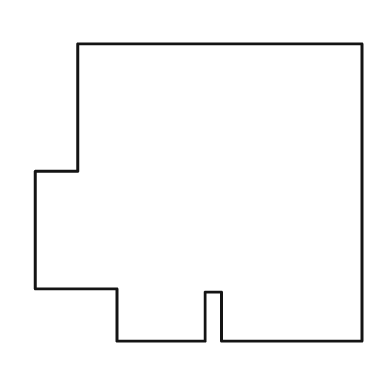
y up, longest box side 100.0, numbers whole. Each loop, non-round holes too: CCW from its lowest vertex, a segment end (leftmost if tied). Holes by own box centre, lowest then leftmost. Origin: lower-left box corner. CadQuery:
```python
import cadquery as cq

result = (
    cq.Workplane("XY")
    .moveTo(25.0, 0.0)
    .lineTo(52.0, 0.0)
    .lineTo(52.0, 15.0)
    .lineTo(57.0, 15.0)
    .lineTo(57.0, 0.0)
    .lineTo(100.0, 0.0)
    .lineTo(100.0, 91.0)
    .lineTo(13.0, 91.0)
    .lineTo(13.0, 52.0)
    .lineTo(0.0, 52.0)
    .lineTo(0.0, 16.0)
    .lineTo(25.0, 16.0)
    .close()
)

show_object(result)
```